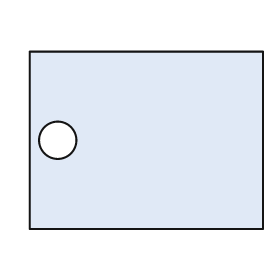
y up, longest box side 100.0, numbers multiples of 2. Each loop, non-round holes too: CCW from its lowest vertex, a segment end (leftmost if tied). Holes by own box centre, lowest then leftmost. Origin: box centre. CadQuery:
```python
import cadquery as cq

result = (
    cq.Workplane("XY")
    .moveTo(-50.0, -38.0)
    .lineTo(50.0, -38.0)
    .lineTo(50.0, 38.0)
    .lineTo(-50.0, 38.0)
    .close()
    .moveTo(-38.0, 0.0)
    .circle(8.0)
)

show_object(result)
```